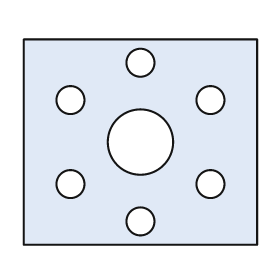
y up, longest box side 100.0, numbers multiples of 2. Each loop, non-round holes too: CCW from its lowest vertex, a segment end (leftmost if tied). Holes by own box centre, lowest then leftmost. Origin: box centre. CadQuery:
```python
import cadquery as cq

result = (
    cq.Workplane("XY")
    .moveTo(-50.0, -44.0)
    .lineTo(50.0, -44.0)
    .lineTo(50.0, 44.0)
    .lineTo(-50.0, 44.0)
    .close()
    .moveTo(0.0, -34.0)
    .circle(6.0)
    .moveTo(-30.0, -18.0)
    .circle(6.0)
    .moveTo(30.0, -18.0)
    .circle(6.0)
    .moveTo(0.0, 0.0)
    .circle(14.0)
    .moveTo(-30.0, 18.0)
    .circle(6.0)
    .moveTo(30.0, 18.0)
    .circle(6.0)
    .moveTo(0.0, 34.0)
    .circle(6.0)
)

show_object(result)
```